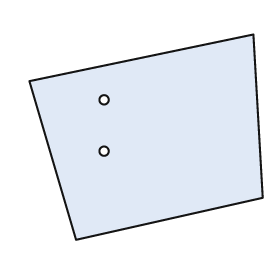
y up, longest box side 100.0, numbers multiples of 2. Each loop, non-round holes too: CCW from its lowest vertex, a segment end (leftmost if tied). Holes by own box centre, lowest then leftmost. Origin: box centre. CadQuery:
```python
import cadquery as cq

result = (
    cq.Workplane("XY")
    .moveTo(-30.0, -44.0)
    .lineTo(50.0, -26.0)
    .lineTo(46.0, 44.0)
    .lineTo(-50.0, 24.0)
    .close()
    .moveTo(-18.0, -6.0)
    .circle(2.0)
    .moveTo(-18.0, 16.0)
    .circle(2.0)
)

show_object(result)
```